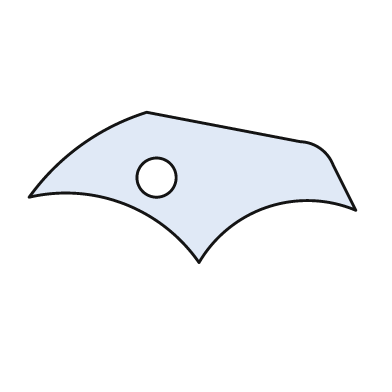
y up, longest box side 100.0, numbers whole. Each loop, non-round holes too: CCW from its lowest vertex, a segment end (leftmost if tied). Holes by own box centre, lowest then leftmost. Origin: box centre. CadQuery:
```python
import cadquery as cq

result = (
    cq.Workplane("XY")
    .moveTo(2.0, -23.0)
    .threePointArc((23.0, -6.0), (50.0, -7.0))
    .lineTo(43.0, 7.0)
    .threePointArc((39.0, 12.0), (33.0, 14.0))
    .lineTo(-14.0, 23.0)
    .threePointArc((-34.0, 13.0), (-50.0, -3.0))
    .threePointArc((-21.0, -5.0), (2.0, -23.0))
    .close()
    .moveTo(-11.0, 3.0)
    .circle(6.0)
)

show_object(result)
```